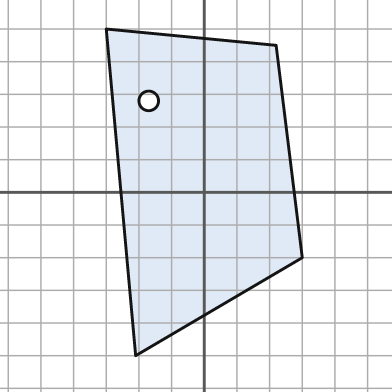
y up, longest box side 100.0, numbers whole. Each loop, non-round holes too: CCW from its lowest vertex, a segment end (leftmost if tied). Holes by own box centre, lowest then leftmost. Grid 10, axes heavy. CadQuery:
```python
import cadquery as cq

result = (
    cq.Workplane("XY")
    .moveTo(-21.0, -50.0)
    .lineTo(30.0, -20.0)
    .lineTo(22.0, 45.0)
    .lineTo(-30.0, 50.0)
    .close()
    .moveTo(-17.0, 28.0)
    .circle(3.0)
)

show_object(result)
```